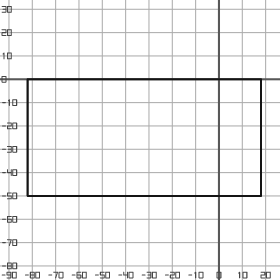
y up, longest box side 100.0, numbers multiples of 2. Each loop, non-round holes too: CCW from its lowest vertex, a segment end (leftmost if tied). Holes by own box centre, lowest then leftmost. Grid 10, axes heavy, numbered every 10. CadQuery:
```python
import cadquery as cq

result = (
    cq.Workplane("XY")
    .moveTo(-82.0, -50.0)
    .lineTo(18.0, -50.0)
    .lineTo(18.0, 0.0)
    .lineTo(-82.0, 0.0)
    .close()
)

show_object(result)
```